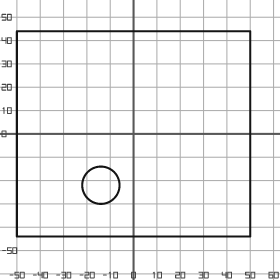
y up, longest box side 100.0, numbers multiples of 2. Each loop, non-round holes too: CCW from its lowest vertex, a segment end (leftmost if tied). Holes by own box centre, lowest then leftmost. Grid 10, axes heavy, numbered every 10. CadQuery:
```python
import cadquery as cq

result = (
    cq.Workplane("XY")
    .moveTo(-50.0, -44.0)
    .lineTo(50.0, -44.0)
    .lineTo(50.0, 44.0)
    .lineTo(-50.0, 44.0)
    .close()
    .moveTo(-14.0, -22.0)
    .circle(8.0)
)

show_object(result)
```